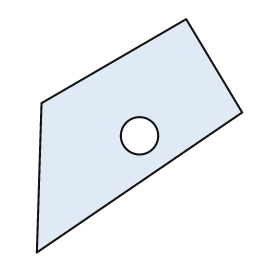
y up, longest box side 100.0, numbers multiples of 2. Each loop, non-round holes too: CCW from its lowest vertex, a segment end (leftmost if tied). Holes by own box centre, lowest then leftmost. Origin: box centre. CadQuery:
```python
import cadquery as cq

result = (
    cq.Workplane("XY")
    .moveTo(-44.0, -50.0)
    .lineTo(44.0, 10.0)
    .lineTo(20.0, 50.0)
    .lineTo(-42.0, 14.0)
    .close()
    .moveTo(0.0, 0.0)
    .circle(8.0)
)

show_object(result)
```